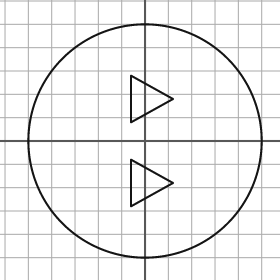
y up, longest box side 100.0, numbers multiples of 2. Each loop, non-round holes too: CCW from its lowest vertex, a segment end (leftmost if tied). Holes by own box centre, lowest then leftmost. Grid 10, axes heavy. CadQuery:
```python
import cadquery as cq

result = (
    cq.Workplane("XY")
    .moveTo(0.0, 0.0)
    .circle(50.0)
    .moveTo(-6.0, -28.0)
    .lineTo(12.0, -18.0)
    .lineTo(-6.0, -8.0)
    .close()
    .moveTo(-6.0, 8.0)
    .lineTo(12.0, 18.0)
    .lineTo(-6.0, 28.0)
    .close()
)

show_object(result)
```